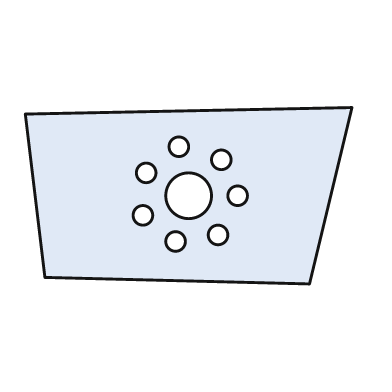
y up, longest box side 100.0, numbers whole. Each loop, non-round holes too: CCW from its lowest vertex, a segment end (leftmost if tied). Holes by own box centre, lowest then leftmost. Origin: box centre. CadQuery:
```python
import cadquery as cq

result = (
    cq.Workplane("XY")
    .moveTo(37.0, -27.0)
    .lineTo(50.0, 27.0)
    .lineTo(-50.0, 25.0)
    .lineTo(-44.0, -25.0)
    .close()
    .moveTo(-4.0, -14.0)
    .circle(3.0)
    .moveTo(9.0, -12.0)
    .circle(3.0)
    .moveTo(-14.0, -6.0)
    .circle(3.0)
    .moveTo(0.0, 0.0)
    .circle(7.0)
    .moveTo(15.0, 0.0)
    .circle(3.0)
    .moveTo(-13.0, 7.0)
    .circle(3.0)
    .moveTo(10.0, 11.0)
    .circle(3.0)
    .moveTo(-3.0, 15.0)
    .circle(3.0)
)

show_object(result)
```